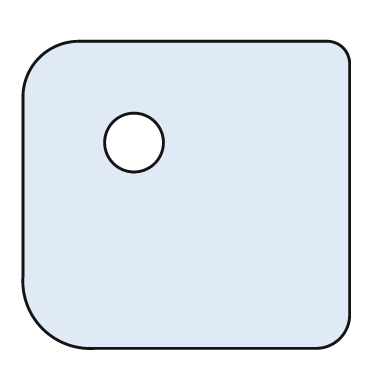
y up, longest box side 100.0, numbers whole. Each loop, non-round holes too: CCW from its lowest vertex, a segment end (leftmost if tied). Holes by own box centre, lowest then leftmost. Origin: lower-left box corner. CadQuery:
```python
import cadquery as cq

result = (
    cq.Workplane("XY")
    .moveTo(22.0, 0.0)
    .lineTo(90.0, 0.0)
    .threePointArc((97.0, 3.0), (100.0, 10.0))
    .lineTo(100.0, 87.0)
    .threePointArc((98.0, 92.0), (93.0, 94.0))
    .lineTo(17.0, 94.0)
    .threePointArc((5.0, 89.0), (0.0, 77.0))
    .lineTo(0.0, 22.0)
    .threePointArc((6.0, 6.0), (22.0, 0.0))
    .close()
    .moveTo(34.0, 63.0)
    .circle(9.0)
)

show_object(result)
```